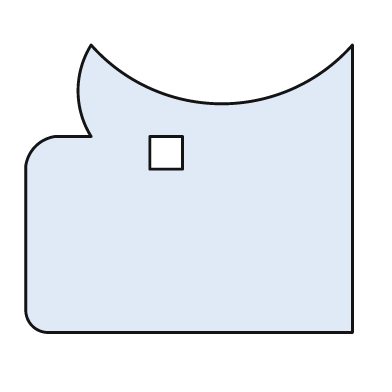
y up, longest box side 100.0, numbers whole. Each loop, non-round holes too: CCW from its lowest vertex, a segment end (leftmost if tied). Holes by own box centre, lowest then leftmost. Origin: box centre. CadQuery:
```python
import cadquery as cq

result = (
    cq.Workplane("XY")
    .moveTo(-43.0, -44.0)
    .lineTo(50.0, -44.0)
    .lineTo(50.0, 44.0)
    .threePointArc((10.0, 26.0), (-30.0, 44.0))
    .threePointArc((-34.0, 30.0), (-30.0, 16.0))
    .lineTo(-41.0, 16.0)
    .threePointArc((-47.0, 13.0), (-50.0, 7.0))
    .lineTo(-50.0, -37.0)
    .threePointArc((-48.0, -42.0), (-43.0, -44.0))
    .close()
    .moveTo(-12.0, 6.0)
    .lineTo(-2.0, 6.0)
    .lineTo(-2.0, 16.0)
    .lineTo(-12.0, 16.0)
    .close()
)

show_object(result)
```